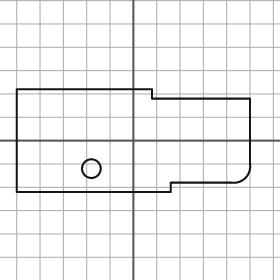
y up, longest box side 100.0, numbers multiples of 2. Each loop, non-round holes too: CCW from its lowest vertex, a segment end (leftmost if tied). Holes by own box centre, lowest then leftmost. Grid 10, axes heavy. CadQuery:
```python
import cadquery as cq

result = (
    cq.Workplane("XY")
    .moveTo(-50.0, -22.0)
    .lineTo(16.0, -22.0)
    .lineTo(16.0, -18.0)
    .lineTo(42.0, -18.0)
    .threePointArc((48.0, -16.0), (50.0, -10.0))
    .lineTo(50.0, 18.0)
    .lineTo(8.0, 18.0)
    .lineTo(8.0, 22.0)
    .lineTo(-50.0, 22.0)
    .close()
    .moveTo(-18.0, -12.0)
    .circle(4.0)
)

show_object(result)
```